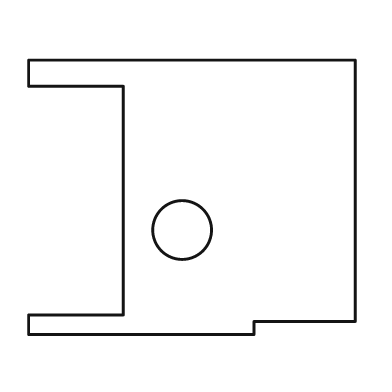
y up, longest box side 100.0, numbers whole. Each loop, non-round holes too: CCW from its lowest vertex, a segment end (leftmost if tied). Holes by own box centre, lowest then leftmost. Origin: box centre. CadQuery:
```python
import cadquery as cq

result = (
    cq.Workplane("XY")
    .moveTo(-50.0, -42.0)
    .lineTo(19.0, -42.0)
    .lineTo(19.0, -38.0)
    .lineTo(50.0, -38.0)
    .lineTo(50.0, 42.0)
    .lineTo(-50.0, 42.0)
    .lineTo(-50.0, 34.0)
    .lineTo(-21.0, 34.0)
    .lineTo(-21.0, -36.0)
    .lineTo(-50.0, -36.0)
    .close()
    .moveTo(-3.0, -10.0)
    .circle(9.0)
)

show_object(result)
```